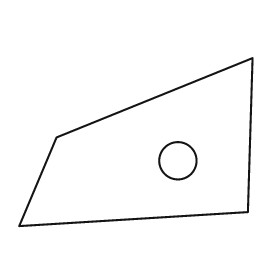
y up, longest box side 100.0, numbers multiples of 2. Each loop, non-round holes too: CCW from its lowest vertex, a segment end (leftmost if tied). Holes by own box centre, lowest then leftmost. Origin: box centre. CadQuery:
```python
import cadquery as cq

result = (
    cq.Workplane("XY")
    .moveTo(-50.0, -36.0)
    .lineTo(48.0, -30.0)
    .lineTo(50.0, 36.0)
    .lineTo(-34.0, 2.0)
    .close()
    .moveTo(18.0, -8.0)
    .circle(8.0)
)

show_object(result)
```